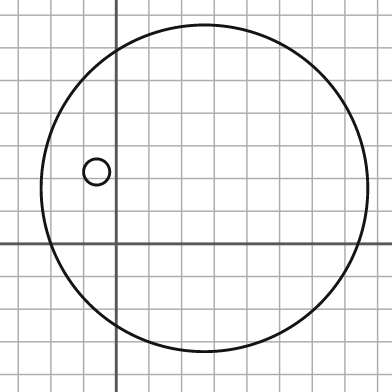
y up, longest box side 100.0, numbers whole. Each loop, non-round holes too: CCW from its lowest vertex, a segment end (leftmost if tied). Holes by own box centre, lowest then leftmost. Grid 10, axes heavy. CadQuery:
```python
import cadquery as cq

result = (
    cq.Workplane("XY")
    .moveTo(27.0, 17.0)
    .circle(50.0)
    .moveTo(-6.0, 22.0)
    .circle(4.0)
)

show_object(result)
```